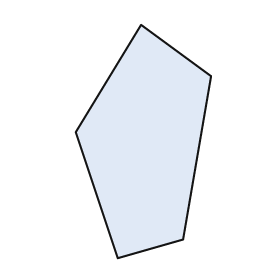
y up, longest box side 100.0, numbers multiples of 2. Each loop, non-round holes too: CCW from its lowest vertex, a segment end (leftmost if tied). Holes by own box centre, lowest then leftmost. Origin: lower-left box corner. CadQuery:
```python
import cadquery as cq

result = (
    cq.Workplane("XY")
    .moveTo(18.0, 0.0)
    .lineTo(46.0, 8.0)
    .lineTo(58.0, 78.0)
    .lineTo(28.0, 100.0)
    .lineTo(0.0, 54.0)
    .close()
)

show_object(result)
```